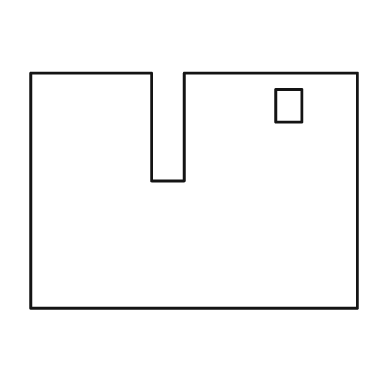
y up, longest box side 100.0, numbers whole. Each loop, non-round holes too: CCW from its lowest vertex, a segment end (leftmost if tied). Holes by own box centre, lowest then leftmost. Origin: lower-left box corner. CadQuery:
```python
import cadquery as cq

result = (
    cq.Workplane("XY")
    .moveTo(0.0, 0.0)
    .lineTo(100.0, 0.0)
    .lineTo(100.0, 72.0)
    .lineTo(47.0, 72.0)
    .lineTo(47.0, 39.0)
    .lineTo(37.0, 39.0)
    .lineTo(37.0, 72.0)
    .lineTo(0.0, 72.0)
    .close()
    .moveTo(75.0, 57.0)
    .lineTo(83.0, 57.0)
    .lineTo(83.0, 67.0)
    .lineTo(75.0, 67.0)
    .close()
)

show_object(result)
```